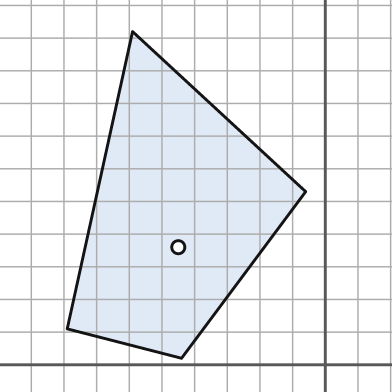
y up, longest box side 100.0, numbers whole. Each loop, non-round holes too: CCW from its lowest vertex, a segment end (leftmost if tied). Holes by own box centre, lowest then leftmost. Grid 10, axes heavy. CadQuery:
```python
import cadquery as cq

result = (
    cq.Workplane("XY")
    .moveTo(-44.0, 2.0)
    .lineTo(-6.0, 53.0)
    .lineTo(-59.0, 102.0)
    .lineTo(-79.0, 11.0)
    .close()
    .moveTo(-45.0, 36.0)
    .circle(2.0)
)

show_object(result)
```